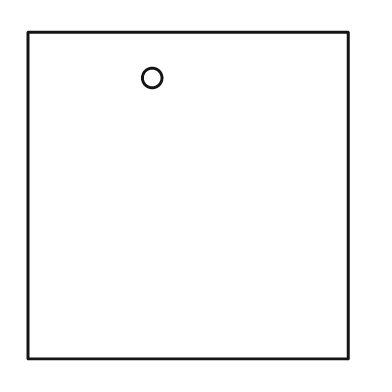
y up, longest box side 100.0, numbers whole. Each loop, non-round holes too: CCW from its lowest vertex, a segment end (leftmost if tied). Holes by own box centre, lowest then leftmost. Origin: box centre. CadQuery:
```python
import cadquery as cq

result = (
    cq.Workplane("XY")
    .moveTo(-49.0, -50.0)
    .lineTo(49.0, -50.0)
    .lineTo(49.0, 50.0)
    .lineTo(-49.0, 50.0)
    .close()
    .moveTo(-11.0, 36.0)
    .circle(3.0)
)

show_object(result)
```